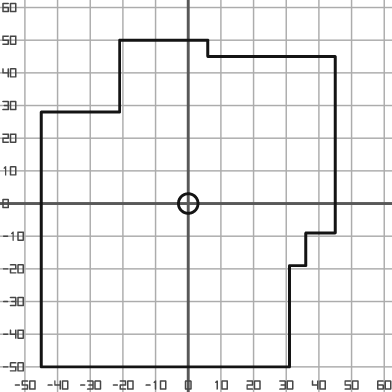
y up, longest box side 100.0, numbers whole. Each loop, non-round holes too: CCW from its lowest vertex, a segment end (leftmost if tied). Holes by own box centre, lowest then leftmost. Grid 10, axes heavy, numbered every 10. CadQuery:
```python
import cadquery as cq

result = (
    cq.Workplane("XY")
    .moveTo(-45.0, -50.0)
    .lineTo(31.0, -50.0)
    .lineTo(31.0, -19.0)
    .lineTo(36.0, -19.0)
    .lineTo(36.0, -9.0)
    .lineTo(45.0, -9.0)
    .lineTo(45.0, 45.0)
    .lineTo(6.0, 45.0)
    .lineTo(6.0, 50.0)
    .lineTo(-21.0, 50.0)
    .lineTo(-21.0, 28.0)
    .lineTo(-45.0, 28.0)
    .close()
    .moveTo(0.0, 0.0)
    .circle(3.0)
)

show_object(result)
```